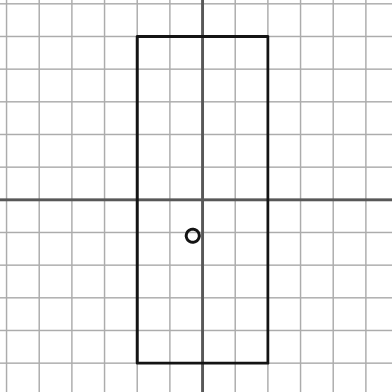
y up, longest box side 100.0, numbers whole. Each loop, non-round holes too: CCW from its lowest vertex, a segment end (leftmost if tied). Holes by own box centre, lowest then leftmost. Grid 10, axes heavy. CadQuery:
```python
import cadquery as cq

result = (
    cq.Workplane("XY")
    .moveTo(-20.0, -50.0)
    .lineTo(20.0, -50.0)
    .lineTo(20.0, 50.0)
    .lineTo(-20.0, 50.0)
    .close()
    .moveTo(-3.0, -11.0)
    .circle(2.0)
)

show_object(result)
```